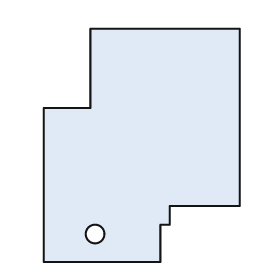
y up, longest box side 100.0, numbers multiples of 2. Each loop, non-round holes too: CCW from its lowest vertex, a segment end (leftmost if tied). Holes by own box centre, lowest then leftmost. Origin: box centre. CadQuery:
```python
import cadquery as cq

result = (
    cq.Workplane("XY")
    .moveTo(-42.0, -50.0)
    .lineTo(8.0, -50.0)
    .lineTo(8.0, -34.0)
    .lineTo(12.0, -34.0)
    .lineTo(12.0, -26.0)
    .lineTo(42.0, -26.0)
    .lineTo(42.0, 50.0)
    .lineTo(-22.0, 50.0)
    .lineTo(-22.0, 16.0)
    .lineTo(-42.0, 16.0)
    .close()
    .moveTo(-20.0, -38.0)
    .circle(4.0)
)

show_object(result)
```